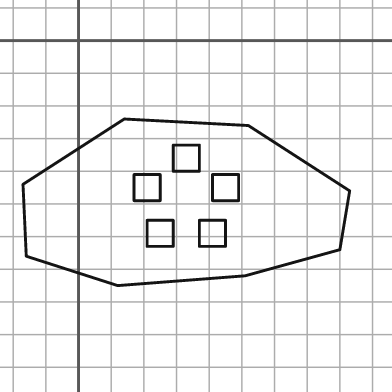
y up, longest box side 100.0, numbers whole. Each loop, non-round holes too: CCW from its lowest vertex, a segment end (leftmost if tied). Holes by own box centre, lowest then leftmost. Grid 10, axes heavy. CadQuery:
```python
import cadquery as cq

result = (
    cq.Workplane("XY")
    .moveTo(12.0, -75.0)
    .lineTo(51.0, -72.0)
    .lineTo(80.0, -64.0)
    .lineTo(83.0, -46.0)
    .lineTo(52.0, -26.0)
    .lineTo(14.0, -24.0)
    .lineTo(-17.0, -44.0)
    .lineTo(-16.0, -66.0)
    .close()
    .moveTo(21.0, -63.0)
    .lineTo(29.0, -63.0)
    .lineTo(29.0, -55.0)
    .lineTo(21.0, -55.0)
    .close()
    .moveTo(37.0, -63.0)
    .lineTo(45.0, -63.0)
    .lineTo(45.0, -55.0)
    .lineTo(37.0, -55.0)
    .close()
    .moveTo(17.0, -49.0)
    .lineTo(25.0, -49.0)
    .lineTo(25.0, -41.0)
    .lineTo(17.0, -41.0)
    .close()
    .moveTo(41.0, -49.0)
    .lineTo(49.0, -49.0)
    .lineTo(49.0, -41.0)
    .lineTo(41.0, -41.0)
    .close()
    .moveTo(29.0, -40.0)
    .lineTo(37.0, -40.0)
    .lineTo(37.0, -32.0)
    .lineTo(29.0, -32.0)
    .close()
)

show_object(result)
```